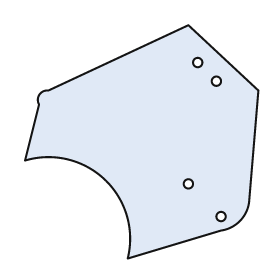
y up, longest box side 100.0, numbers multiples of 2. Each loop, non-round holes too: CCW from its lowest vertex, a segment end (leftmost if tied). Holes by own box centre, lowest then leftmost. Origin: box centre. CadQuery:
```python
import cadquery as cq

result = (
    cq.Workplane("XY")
    .moveTo(-6.0, -50.0)
    .lineTo(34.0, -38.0)
    .threePointArc((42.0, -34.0), (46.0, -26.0))
    .lineTo(50.0, 22.0)
    .lineTo(20.0, 50.0)
    .lineTo(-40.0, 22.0)
    .threePointArc((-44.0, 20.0), (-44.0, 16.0))
    .lineTo(-50.0, -8.0)
    .threePointArc((-16.0, -16.0), (-6.0, -50.0))
    .close()
    .moveTo(34.0, -32.0)
    .circle(2.0)
    .moveTo(20.0, -18.0)
    .circle(2.0)
    .moveTo(32.0, 26.0)
    .circle(2.0)
    .moveTo(24.0, 34.0)
    .circle(2.0)
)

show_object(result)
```